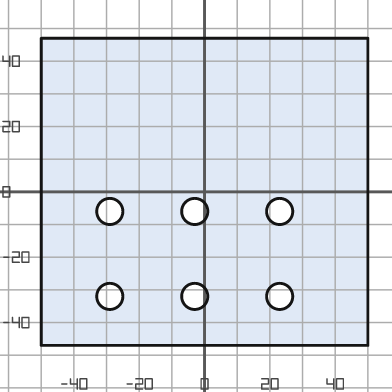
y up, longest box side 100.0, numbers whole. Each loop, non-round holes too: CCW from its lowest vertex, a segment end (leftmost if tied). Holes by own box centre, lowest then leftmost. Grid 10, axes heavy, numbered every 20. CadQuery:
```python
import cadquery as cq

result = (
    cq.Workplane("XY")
    .moveTo(-50.0, -47.0)
    .lineTo(50.0, -47.0)
    .lineTo(50.0, 47.0)
    .lineTo(-50.0, 47.0)
    .close()
    .moveTo(-29.0, -32.0)
    .circle(4.0)
    .moveTo(-3.0, -32.0)
    .circle(4.0)
    .moveTo(23.0, -32.0)
    .circle(4.0)
    .moveTo(-29.0, -6.0)
    .circle(4.0)
    .moveTo(-3.0, -6.0)
    .circle(4.0)
    .moveTo(23.0, -6.0)
    .circle(4.0)
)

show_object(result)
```